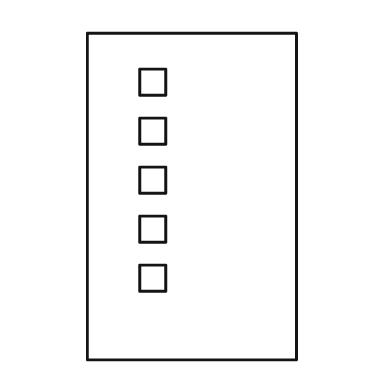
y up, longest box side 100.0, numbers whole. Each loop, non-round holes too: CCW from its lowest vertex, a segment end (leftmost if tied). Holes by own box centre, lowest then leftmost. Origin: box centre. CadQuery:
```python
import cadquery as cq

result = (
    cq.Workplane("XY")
    .moveTo(-32.0, -50.0)
    .lineTo(32.0, -50.0)
    .lineTo(32.0, 50.0)
    .lineTo(-32.0, 50.0)
    .close()
    .moveTo(-16.0, -29.0)
    .lineTo(-8.0, -29.0)
    .lineTo(-8.0, -21.0)
    .lineTo(-16.0, -21.0)
    .close()
    .moveTo(-16.0, -14.0)
    .lineTo(-8.0, -14.0)
    .lineTo(-8.0, -6.0)
    .lineTo(-16.0, -6.0)
    .close()
    .moveTo(-16.0, 1.0)
    .lineTo(-8.0, 1.0)
    .lineTo(-8.0, 9.0)
    .lineTo(-16.0, 9.0)
    .close()
    .moveTo(-16.0, 16.0)
    .lineTo(-8.0, 16.0)
    .lineTo(-8.0, 24.0)
    .lineTo(-16.0, 24.0)
    .close()
    .moveTo(-16.0, 31.0)
    .lineTo(-8.0, 31.0)
    .lineTo(-8.0, 39.0)
    .lineTo(-16.0, 39.0)
    .close()
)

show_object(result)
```